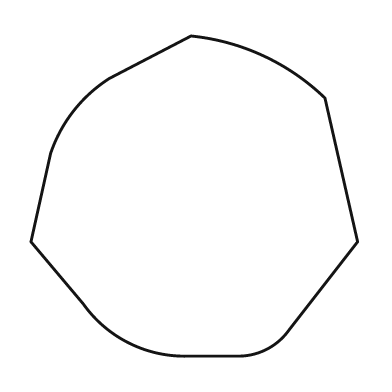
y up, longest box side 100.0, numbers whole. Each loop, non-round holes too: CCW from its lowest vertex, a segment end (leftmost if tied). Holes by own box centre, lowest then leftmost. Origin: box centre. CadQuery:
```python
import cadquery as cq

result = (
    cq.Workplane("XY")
    .moveTo(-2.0, -49.0)
    .lineTo(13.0, -49.0)
    .threePointArc((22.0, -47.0), (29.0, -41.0))
    .lineTo(50.0, -14.0)
    .lineTo(40.0, 30.0)
    .threePointArc((21.0, 43.0), (-1.0, 49.0))
    .lineTo(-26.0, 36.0)
    .threePointArc((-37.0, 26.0), (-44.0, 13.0))
    .lineTo(-50.0, -14.0)
    .lineTo(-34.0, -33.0)
    .threePointArc((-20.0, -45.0), (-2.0, -49.0))
    .close()
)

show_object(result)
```